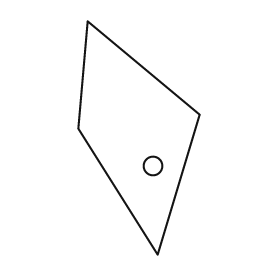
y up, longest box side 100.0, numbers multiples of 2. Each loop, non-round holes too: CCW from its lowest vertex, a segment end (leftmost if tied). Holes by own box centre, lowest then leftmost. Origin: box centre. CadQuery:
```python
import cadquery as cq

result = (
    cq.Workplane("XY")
    .moveTo(8.0, -50.0)
    .lineTo(26.0, 10.0)
    .lineTo(-22.0, 50.0)
    .lineTo(-26.0, 4.0)
    .close()
    .moveTo(6.0, -12.0)
    .circle(4.0)
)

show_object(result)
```